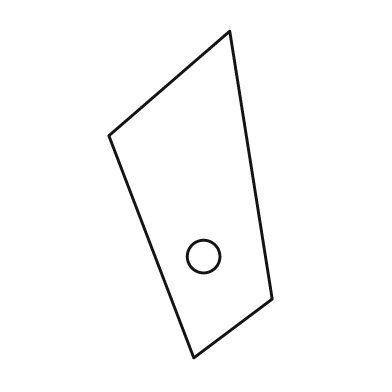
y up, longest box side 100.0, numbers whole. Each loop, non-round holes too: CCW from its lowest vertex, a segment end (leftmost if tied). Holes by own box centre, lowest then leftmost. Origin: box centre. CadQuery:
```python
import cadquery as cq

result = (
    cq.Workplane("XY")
    .moveTo(1.0, -50.0)
    .lineTo(25.0, -32.0)
    .lineTo(12.0, 50.0)
    .lineTo(-25.0, 18.0)
    .close()
    .moveTo(4.0, -19.0)
    .circle(5.0)
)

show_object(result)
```